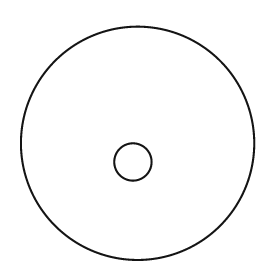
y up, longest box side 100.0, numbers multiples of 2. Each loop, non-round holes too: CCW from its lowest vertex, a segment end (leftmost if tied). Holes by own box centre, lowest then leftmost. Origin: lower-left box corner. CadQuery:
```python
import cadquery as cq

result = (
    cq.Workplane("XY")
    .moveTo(50.0, 50.0)
    .circle(50.0)
    .moveTo(48.0, 42.0)
    .circle(8.0)
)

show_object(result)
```